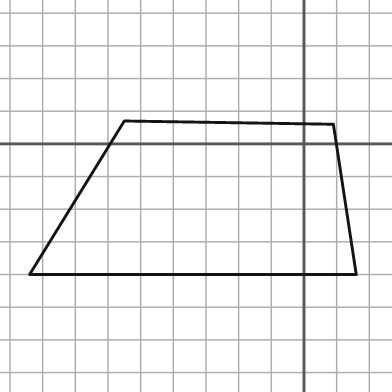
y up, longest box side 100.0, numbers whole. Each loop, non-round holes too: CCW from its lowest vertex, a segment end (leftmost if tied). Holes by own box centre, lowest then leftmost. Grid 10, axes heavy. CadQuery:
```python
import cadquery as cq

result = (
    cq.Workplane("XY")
    .moveTo(-84.0, -40.0)
    .lineTo(16.0, -40.0)
    .lineTo(9.0, 6.0)
    .lineTo(-55.0, 7.0)
    .close()
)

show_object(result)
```